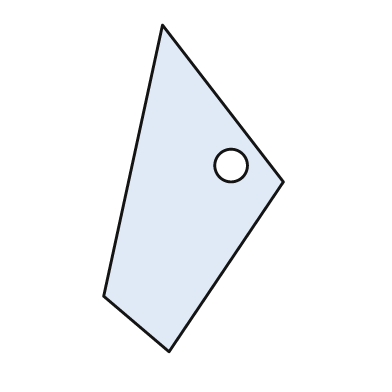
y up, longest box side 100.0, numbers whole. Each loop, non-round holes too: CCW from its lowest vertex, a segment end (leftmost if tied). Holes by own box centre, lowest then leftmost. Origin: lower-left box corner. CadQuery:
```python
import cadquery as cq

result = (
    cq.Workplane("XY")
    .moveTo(20.0, 0.0)
    .lineTo(55.0, 52.0)
    .lineTo(18.0, 100.0)
    .lineTo(0.0, 17.0)
    .close()
    .moveTo(39.0, 57.0)
    .circle(5.0)
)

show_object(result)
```